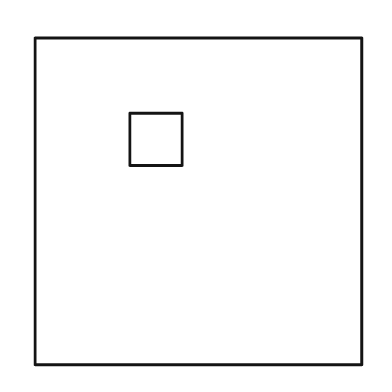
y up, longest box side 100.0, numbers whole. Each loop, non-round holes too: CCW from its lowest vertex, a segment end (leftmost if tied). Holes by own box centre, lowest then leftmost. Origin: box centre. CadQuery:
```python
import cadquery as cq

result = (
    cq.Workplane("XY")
    .moveTo(-50.0, -50.0)
    .lineTo(50.0, -50.0)
    .lineTo(50.0, 50.0)
    .lineTo(-50.0, 50.0)
    .close()
    .moveTo(-21.0, 11.0)
    .lineTo(-5.0, 11.0)
    .lineTo(-5.0, 27.0)
    .lineTo(-21.0, 27.0)
    .close()
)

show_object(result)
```